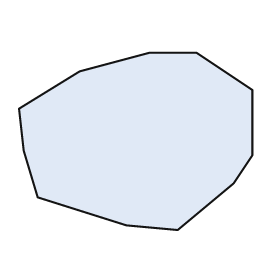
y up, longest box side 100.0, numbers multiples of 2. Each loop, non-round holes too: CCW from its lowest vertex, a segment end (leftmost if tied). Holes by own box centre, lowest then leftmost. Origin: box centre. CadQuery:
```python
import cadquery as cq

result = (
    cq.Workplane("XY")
    .moveTo(18.0, -38.0)
    .lineTo(42.0, -18.0)
    .lineTo(50.0, -6.0)
    .lineTo(50.0, 22.0)
    .lineTo(26.0, 38.0)
    .lineTo(6.0, 38.0)
    .lineTo(-24.0, 30.0)
    .lineTo(-50.0, 14.0)
    .lineTo(-48.0, -4.0)
    .lineTo(-42.0, -24.0)
    .lineTo(-4.0, -36.0)
    .close()
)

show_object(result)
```